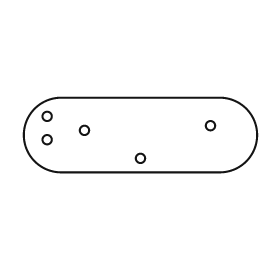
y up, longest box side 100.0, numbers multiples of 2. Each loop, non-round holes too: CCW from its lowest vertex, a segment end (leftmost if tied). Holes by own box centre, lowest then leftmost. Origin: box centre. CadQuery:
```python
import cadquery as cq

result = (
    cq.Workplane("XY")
    .moveTo(-34.0, -16.0)
    .lineTo(34.0, -16.0)
    .threePointArc((50.0, 0.0), (34.0, 16.0))
    .lineTo(-34.0, 16.0)
    .threePointArc((-50.0, 0.0), (-34.0, -16.0))
    .close()
    .moveTo(0.0, -10.0)
    .circle(2.0)
    .moveTo(-40.0, -2.0)
    .circle(2.0)
    .moveTo(-24.0, 2.0)
    .circle(2.0)
    .moveTo(30.0, 4.0)
    .circle(2.0)
    .moveTo(-40.0, 8.0)
    .circle(2.0)
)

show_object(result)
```